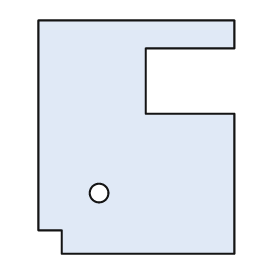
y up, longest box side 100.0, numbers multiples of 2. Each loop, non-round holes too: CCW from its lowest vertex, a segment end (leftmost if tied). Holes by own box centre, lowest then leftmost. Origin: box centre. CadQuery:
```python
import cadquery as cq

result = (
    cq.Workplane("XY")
    .moveTo(-32.0, -50.0)
    .lineTo(42.0, -50.0)
    .lineTo(42.0, 10.0)
    .lineTo(4.0, 10.0)
    .lineTo(4.0, 38.0)
    .lineTo(42.0, 38.0)
    .lineTo(42.0, 50.0)
    .lineTo(-42.0, 50.0)
    .lineTo(-42.0, -40.0)
    .lineTo(-32.0, -40.0)
    .close()
    .moveTo(-16.0, -24.0)
    .circle(4.0)
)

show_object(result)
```